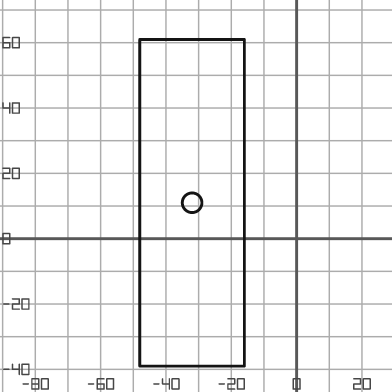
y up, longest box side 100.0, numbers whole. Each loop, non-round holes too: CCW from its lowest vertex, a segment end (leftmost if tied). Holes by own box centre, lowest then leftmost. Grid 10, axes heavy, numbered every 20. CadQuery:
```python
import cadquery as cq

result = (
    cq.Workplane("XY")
    .moveTo(-48.0, -39.0)
    .lineTo(-16.0, -39.0)
    .lineTo(-16.0, 61.0)
    .lineTo(-48.0, 61.0)
    .close()
    .moveTo(-32.0, 11.0)
    .circle(3.0)
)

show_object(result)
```